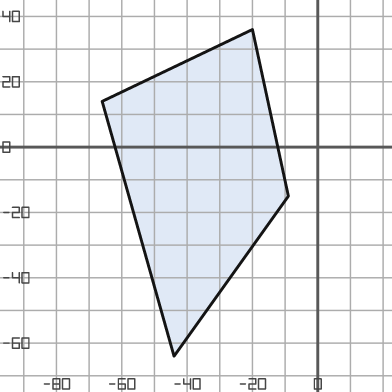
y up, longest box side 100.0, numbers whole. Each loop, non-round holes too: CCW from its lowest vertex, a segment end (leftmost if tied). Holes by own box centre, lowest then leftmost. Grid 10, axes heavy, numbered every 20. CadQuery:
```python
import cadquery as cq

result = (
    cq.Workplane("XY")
    .moveTo(-44.0, -64.0)
    .lineTo(-9.0, -15.0)
    .lineTo(-20.0, 36.0)
    .lineTo(-66.0, 14.0)
    .close()
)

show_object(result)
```